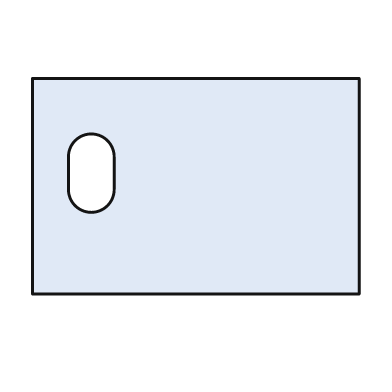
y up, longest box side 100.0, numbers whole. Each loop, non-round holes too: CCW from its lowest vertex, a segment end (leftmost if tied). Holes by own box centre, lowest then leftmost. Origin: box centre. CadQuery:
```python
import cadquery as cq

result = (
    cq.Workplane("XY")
    .moveTo(-50.0, -33.0)
    .lineTo(50.0, -33.0)
    .lineTo(50.0, 33.0)
    .lineTo(-50.0, 33.0)
    .close()
    .moveTo(-39.0, -1.0)
    .threePointArc((-32.0, -8.0), (-25.0, -1.0))
    .lineTo(-25.0, 9.0)
    .threePointArc((-32.0, 16.0), (-39.0, 9.0))
    .close()
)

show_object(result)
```